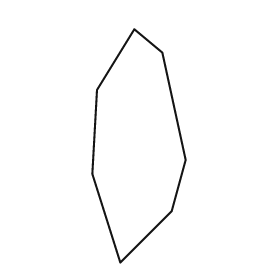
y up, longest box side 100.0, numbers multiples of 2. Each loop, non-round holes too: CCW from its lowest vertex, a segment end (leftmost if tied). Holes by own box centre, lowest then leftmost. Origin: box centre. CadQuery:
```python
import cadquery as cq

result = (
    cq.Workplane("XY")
    .moveTo(-8.0, -50.0)
    .lineTo(14.0, -28.0)
    .lineTo(20.0, -6.0)
    .lineTo(10.0, 40.0)
    .lineTo(-2.0, 50.0)
    .lineTo(-18.0, 24.0)
    .lineTo(-20.0, -12.0)
    .close()
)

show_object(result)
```